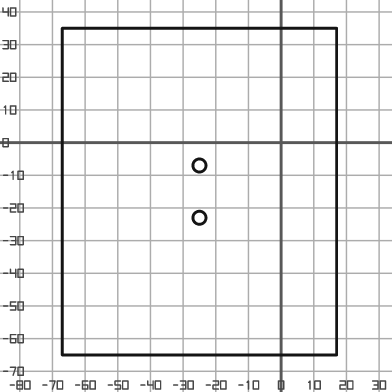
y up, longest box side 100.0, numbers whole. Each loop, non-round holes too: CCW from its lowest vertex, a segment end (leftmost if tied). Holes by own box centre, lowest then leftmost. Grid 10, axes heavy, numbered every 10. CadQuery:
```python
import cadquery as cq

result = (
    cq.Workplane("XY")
    .moveTo(-67.0, -65.0)
    .lineTo(17.0, -65.0)
    .lineTo(17.0, 35.0)
    .lineTo(-67.0, 35.0)
    .close()
    .moveTo(-25.0, -23.0)
    .circle(2.0)
    .moveTo(-25.0, -7.0)
    .circle(2.0)
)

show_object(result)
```